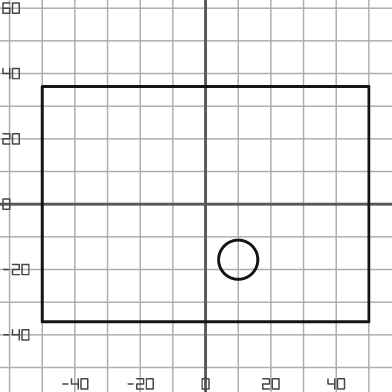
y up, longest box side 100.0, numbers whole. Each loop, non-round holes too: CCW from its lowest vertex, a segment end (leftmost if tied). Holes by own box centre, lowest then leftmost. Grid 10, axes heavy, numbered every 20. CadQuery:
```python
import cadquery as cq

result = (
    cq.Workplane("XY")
    .moveTo(-50.0, -36.0)
    .lineTo(50.0, -36.0)
    .lineTo(50.0, 36.0)
    .lineTo(-50.0, 36.0)
    .close()
    .moveTo(10.0, -17.0)
    .circle(6.0)
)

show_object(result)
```